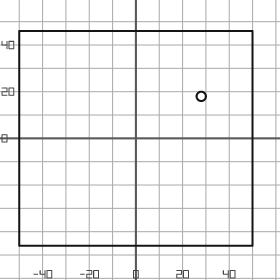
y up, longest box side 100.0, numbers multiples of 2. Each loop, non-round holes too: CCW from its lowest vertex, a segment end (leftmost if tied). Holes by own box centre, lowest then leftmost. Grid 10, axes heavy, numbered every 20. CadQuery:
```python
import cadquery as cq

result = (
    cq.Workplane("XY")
    .moveTo(-50.0, -46.0)
    .lineTo(50.0, -46.0)
    .lineTo(50.0, 46.0)
    .lineTo(-50.0, 46.0)
    .close()
    .moveTo(28.0, 18.0)
    .circle(2.0)
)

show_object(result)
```